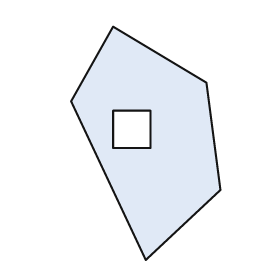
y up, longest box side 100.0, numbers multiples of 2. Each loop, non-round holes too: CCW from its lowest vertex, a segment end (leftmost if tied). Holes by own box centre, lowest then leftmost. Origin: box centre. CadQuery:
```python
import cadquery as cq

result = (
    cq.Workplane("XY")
    .moveTo(0.0, -50.0)
    .lineTo(32.0, -20.0)
    .lineTo(26.0, 26.0)
    .lineTo(-14.0, 50.0)
    .lineTo(-32.0, 18.0)
    .close()
    .moveTo(-14.0, -2.0)
    .lineTo(2.0, -2.0)
    .lineTo(2.0, 14.0)
    .lineTo(-14.0, 14.0)
    .close()
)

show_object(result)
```